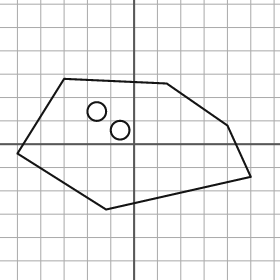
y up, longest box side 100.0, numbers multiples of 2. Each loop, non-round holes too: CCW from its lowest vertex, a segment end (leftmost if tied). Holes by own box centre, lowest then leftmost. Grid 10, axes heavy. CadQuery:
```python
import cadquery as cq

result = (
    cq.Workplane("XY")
    .moveTo(-12.0, -28.0)
    .lineTo(50.0, -14.0)
    .lineTo(40.0, 8.0)
    .lineTo(14.0, 26.0)
    .lineTo(-30.0, 28.0)
    .lineTo(-50.0, -4.0)
    .close()
    .moveTo(-6.0, 6.0)
    .circle(4.0)
    .moveTo(-16.0, 14.0)
    .circle(4.0)
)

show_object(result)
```